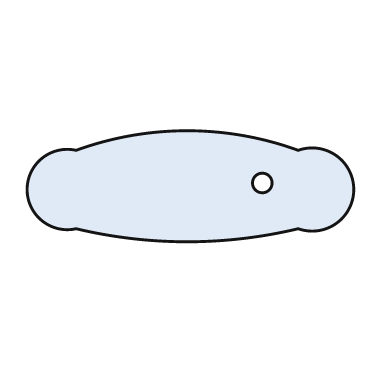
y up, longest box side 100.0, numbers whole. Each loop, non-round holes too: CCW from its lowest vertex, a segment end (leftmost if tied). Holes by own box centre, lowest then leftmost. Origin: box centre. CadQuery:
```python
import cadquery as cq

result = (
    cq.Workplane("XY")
    .moveTo(-35.0, -13.0)
    .threePointArc((-1.0, -17.0), (33.0, -13.0))
    .threePointArc((50.0, -1.0), (33.0, 11.0))
    .threePointArc((-1.0, 17.0), (-35.0, 11.0))
    .threePointArc((-50.0, -1.0), (-35.0, -13.0))
    .close()
    .moveTo(22.0, 1.0)
    .circle(3.0)
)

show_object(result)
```